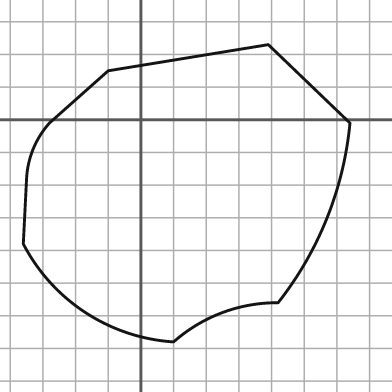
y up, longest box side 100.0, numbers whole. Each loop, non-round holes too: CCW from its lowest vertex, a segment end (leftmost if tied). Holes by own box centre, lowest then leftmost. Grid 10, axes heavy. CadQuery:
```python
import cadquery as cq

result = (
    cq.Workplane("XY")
    .moveTo(10.0, -68.0)
    .threePointArc((25.0, -59.0), (42.0, -56.0))
    .threePointArc((57.0, -30.0), (64.0, -1.0))
    .lineTo(39.0, 23.0)
    .lineTo(-10.0, 15.0)
    .lineTo(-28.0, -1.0)
    .threePointArc((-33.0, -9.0), (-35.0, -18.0))
    .lineTo(-36.0, -38.0)
    .threePointArc((-17.0, -59.0), (10.0, -68.0))
    .close()
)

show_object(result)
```